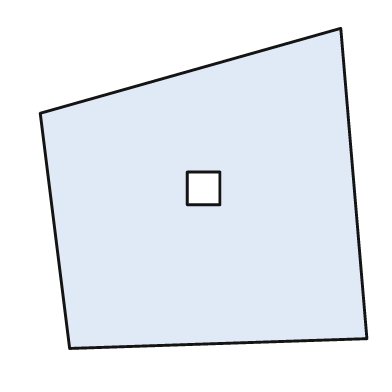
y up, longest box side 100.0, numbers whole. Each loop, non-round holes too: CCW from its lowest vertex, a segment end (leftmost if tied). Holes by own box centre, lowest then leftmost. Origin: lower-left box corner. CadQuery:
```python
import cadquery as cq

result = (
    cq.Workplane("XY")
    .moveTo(9.0, 0.0)
    .lineTo(100.0, 3.0)
    .lineTo(92.0, 98.0)
    .lineTo(0.0, 72.0)
    .close()
    .moveTo(45.0, 44.0)
    .lineTo(55.0, 44.0)
    .lineTo(55.0, 54.0)
    .lineTo(45.0, 54.0)
    .close()
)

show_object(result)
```